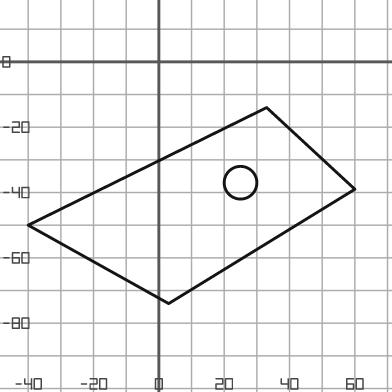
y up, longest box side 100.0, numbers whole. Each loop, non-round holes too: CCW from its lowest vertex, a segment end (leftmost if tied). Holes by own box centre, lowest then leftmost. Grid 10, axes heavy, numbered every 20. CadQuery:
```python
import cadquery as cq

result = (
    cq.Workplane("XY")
    .moveTo(3.0, -74.0)
    .lineTo(60.0, -39.0)
    .lineTo(33.0, -14.0)
    .lineTo(-40.0, -50.0)
    .close()
    .moveTo(25.0, -37.0)
    .circle(5.0)
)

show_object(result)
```